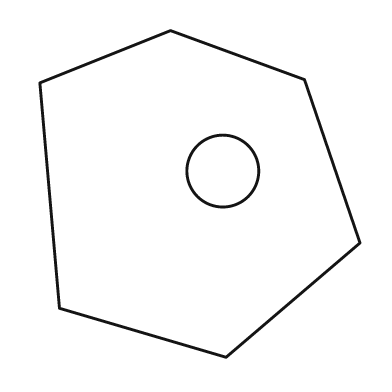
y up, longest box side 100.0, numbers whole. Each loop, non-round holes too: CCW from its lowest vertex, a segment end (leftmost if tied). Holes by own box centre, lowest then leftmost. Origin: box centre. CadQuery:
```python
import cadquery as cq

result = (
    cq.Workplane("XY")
    .moveTo(8.0, -50.0)
    .lineTo(49.0, -15.0)
    .lineTo(32.0, 35.0)
    .lineTo(-9.0, 50.0)
    .lineTo(-49.0, 34.0)
    .lineTo(-43.0, -35.0)
    .close()
    .moveTo(7.0, 7.0)
    .circle(11.0)
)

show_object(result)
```